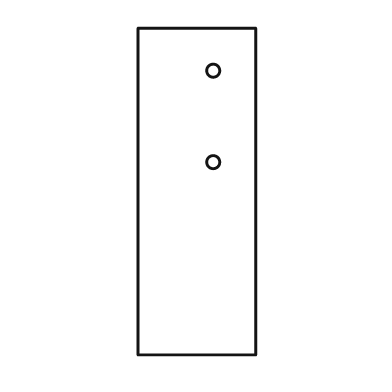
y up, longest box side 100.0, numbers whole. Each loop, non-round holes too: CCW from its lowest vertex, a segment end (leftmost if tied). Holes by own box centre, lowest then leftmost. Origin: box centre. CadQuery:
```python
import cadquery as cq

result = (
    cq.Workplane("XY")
    .moveTo(-18.0, -50.0)
    .lineTo(18.0, -50.0)
    .lineTo(18.0, 50.0)
    .lineTo(-18.0, 50.0)
    .close()
    .moveTo(5.0, 9.0)
    .circle(2.0)
    .moveTo(5.0, 37.0)
    .circle(2.0)
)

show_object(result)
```